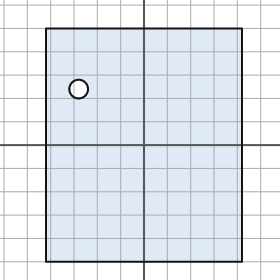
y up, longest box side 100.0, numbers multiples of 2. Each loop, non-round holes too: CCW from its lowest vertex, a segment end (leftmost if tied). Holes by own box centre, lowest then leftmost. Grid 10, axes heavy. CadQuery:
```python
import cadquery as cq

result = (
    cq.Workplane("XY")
    .moveTo(-42.0, -50.0)
    .lineTo(42.0, -50.0)
    .lineTo(42.0, 50.0)
    .lineTo(-42.0, 50.0)
    .close()
    .moveTo(-28.0, 24.0)
    .circle(4.0)
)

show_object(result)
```